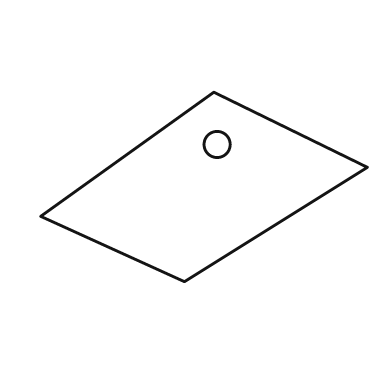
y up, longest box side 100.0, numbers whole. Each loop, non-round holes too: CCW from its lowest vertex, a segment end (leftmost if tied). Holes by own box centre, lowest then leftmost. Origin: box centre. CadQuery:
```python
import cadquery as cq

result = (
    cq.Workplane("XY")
    .moveTo(-6.0, -29.0)
    .lineTo(50.0, 6.0)
    .lineTo(3.0, 29.0)
    .lineTo(-50.0, -9.0)
    .close()
    .moveTo(4.0, 13.0)
    .circle(4.0)
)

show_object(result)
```